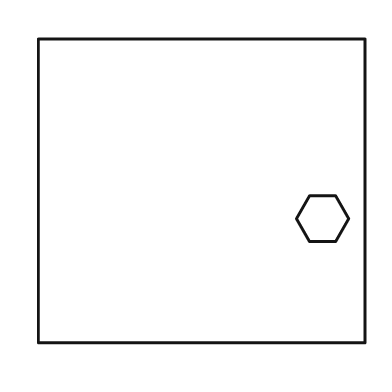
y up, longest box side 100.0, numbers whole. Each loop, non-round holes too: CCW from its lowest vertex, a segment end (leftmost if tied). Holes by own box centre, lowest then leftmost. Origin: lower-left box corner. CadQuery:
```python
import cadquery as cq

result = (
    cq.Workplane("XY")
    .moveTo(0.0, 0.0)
    .lineTo(100.0, 0.0)
    .lineTo(100.0, 93.0)
    .lineTo(0.0, 93.0)
    .close()
    .moveTo(83.0, 31.0)
    .lineTo(91.0, 31.0)
    .lineTo(95.0, 38.0)
    .lineTo(91.0, 45.0)
    .lineTo(83.0, 45.0)
    .lineTo(79.0, 38.0)
    .close()
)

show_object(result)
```